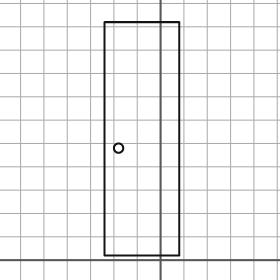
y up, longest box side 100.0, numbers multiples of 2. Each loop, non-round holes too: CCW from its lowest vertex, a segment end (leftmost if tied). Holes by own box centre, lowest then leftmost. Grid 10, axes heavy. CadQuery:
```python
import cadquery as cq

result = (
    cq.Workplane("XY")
    .moveTo(-24.0, 2.0)
    .lineTo(8.0, 2.0)
    .lineTo(8.0, 102.0)
    .lineTo(-24.0, 102.0)
    .close()
    .moveTo(-18.0, 48.0)
    .circle(2.0)
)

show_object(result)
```